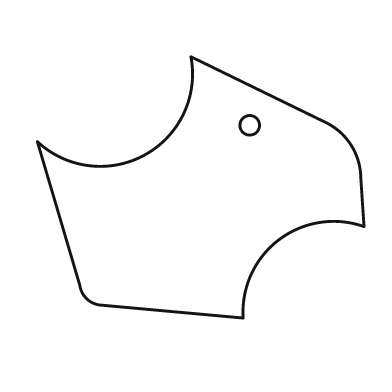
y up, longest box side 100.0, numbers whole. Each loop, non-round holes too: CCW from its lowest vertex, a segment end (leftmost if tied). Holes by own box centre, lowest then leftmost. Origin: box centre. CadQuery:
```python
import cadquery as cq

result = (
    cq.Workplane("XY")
    .moveTo(13.0, -40.0)
    .threePointArc((24.0, -16.0), (50.0, -12.0))
    .lineTo(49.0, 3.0)
    .threePointArc((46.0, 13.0), (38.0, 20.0))
    .lineTo(-3.0, 40.0)
    .threePointArc((-17.0, 10.0), (-50.0, 14.0))
    .lineTo(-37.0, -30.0)
    .threePointArc((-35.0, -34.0), (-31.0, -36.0))
    .close()
    .moveTo(15.0, 19.0)
    .circle(3.0)
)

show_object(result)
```